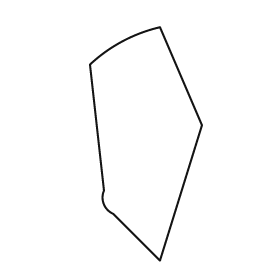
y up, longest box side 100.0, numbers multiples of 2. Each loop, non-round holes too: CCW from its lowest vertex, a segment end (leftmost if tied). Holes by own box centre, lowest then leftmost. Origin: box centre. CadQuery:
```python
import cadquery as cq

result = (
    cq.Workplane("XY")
    .moveTo(6.0, -50.0)
    .lineTo(24.0, 8.0)
    .lineTo(6.0, 50.0)
    .threePointArc((-10.0, 44.0), (-24.0, 34.0))
    .lineTo(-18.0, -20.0)
    .threePointArc((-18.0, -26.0), (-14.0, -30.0))
    .close()
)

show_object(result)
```